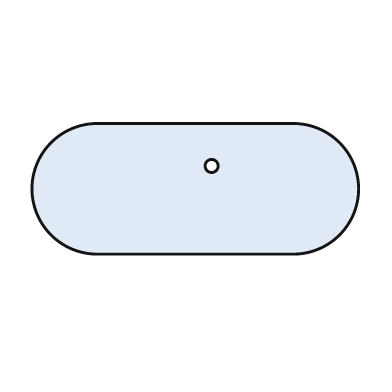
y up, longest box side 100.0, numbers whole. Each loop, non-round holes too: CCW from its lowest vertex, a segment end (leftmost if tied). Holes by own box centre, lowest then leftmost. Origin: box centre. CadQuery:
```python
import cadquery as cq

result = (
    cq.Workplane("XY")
    .moveTo(-30.0, -20.0)
    .lineTo(30.0, -20.0)
    .threePointArc((50.0, 0.0), (30.0, 20.0))
    .lineTo(-30.0, 20.0)
    .threePointArc((-50.0, 0.0), (-30.0, -20.0))
    .close()
    .moveTo(5.0, 7.0)
    .circle(2.0)
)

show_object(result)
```